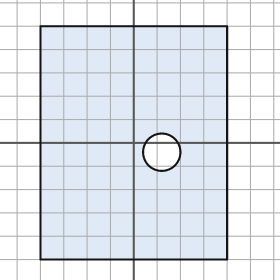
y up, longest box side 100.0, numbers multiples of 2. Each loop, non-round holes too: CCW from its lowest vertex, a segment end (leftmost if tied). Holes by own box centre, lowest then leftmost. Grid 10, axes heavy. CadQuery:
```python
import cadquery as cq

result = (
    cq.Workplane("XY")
    .moveTo(-40.0, -50.0)
    .lineTo(40.0, -50.0)
    .lineTo(40.0, 50.0)
    .lineTo(-40.0, 50.0)
    .close()
    .moveTo(12.0, -4.0)
    .circle(8.0)
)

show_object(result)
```